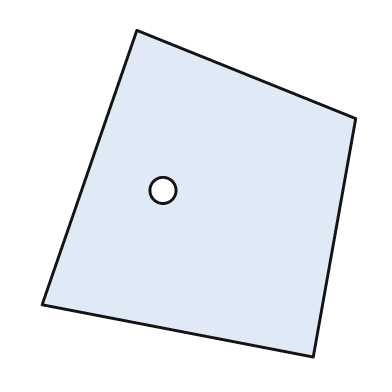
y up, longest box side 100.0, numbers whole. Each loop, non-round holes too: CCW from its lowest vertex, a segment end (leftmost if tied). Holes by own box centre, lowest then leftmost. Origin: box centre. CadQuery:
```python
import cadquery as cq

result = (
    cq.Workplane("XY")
    .moveTo(35.0, -50.0)
    .lineTo(48.0, 23.0)
    .lineTo(-19.0, 50.0)
    .lineTo(-48.0, -34.0)
    .close()
    .moveTo(-11.0, 1.0)
    .circle(4.0)
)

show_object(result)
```